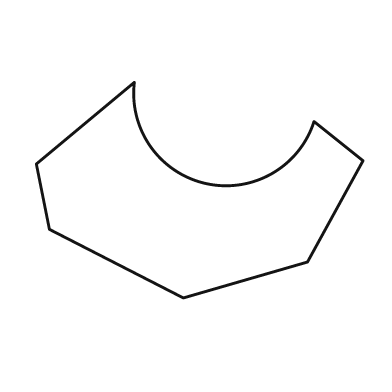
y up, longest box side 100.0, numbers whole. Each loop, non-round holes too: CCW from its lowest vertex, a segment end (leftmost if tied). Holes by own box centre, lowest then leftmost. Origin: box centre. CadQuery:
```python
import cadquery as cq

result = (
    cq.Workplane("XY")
    .moveTo(-5.0, -33.0)
    .lineTo(33.0, -22.0)
    .lineTo(50.0, 9.0)
    .lineTo(35.0, 21.0)
    .threePointArc((2.0, 2.0), (-20.0, 33.0))
    .lineTo(-50.0, 8.0)
    .lineTo(-46.0, -12.0)
    .close()
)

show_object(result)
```